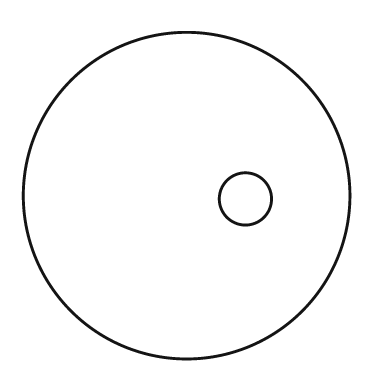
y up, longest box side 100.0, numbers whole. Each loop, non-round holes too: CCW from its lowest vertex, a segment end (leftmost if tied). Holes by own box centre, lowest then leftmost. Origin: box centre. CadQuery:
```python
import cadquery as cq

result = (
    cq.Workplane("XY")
    .moveTo(0.0, 0.0)
    .circle(50.0)
    .moveTo(18.0, -1.0)
    .circle(8.0)
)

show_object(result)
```